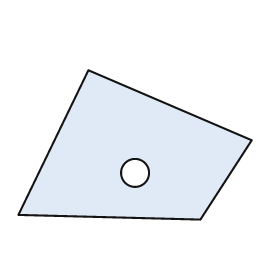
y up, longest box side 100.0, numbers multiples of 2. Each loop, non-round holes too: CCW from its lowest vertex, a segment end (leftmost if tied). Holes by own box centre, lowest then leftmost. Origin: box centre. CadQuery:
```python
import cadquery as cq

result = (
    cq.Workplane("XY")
    .moveTo(28.0, -32.0)
    .lineTo(50.0, 2.0)
    .lineTo(-20.0, 32.0)
    .lineTo(-50.0, -30.0)
    .close()
    .moveTo(0.0, -12.0)
    .circle(6.0)
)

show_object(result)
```